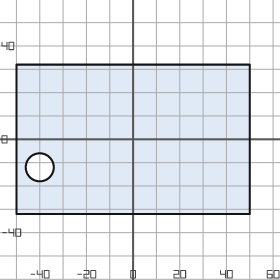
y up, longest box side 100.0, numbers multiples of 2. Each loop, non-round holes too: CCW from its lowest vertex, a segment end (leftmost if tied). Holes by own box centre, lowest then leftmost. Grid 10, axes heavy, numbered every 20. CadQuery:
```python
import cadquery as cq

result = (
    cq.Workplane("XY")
    .moveTo(-50.0, -32.0)
    .lineTo(50.0, -32.0)
    .lineTo(50.0, 32.0)
    .lineTo(-50.0, 32.0)
    .close()
    .moveTo(-40.0, -12.0)
    .circle(6.0)
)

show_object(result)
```